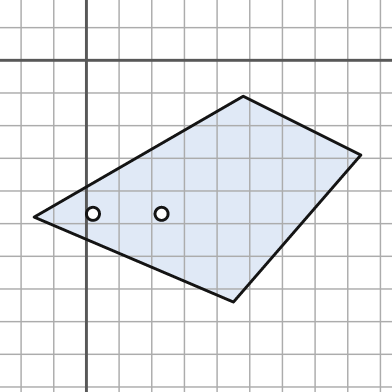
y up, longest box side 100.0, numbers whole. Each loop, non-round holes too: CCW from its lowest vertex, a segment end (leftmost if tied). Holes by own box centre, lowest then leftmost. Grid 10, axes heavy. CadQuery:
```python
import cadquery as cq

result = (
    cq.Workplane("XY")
    .moveTo(45.0, -74.0)
    .lineTo(84.0, -29.0)
    .lineTo(48.0, -11.0)
    .lineTo(-16.0, -48.0)
    .close()
    .moveTo(2.0, -47.0)
    .circle(2.0)
    .moveTo(23.0, -47.0)
    .circle(2.0)
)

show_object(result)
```